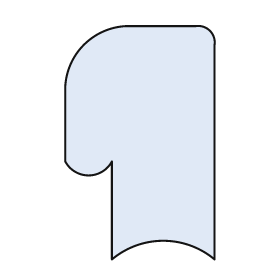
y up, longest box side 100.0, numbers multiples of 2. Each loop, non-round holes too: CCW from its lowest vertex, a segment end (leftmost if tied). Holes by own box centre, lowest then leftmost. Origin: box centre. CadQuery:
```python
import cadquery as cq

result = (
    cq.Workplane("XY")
    .moveTo(-12.0, -50.0)
    .threePointArc((10.0, -42.0), (32.0, -50.0))
    .lineTo(32.0, 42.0)
    .threePointArc((30.0, 48.0), (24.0, 50.0))
    .lineTo(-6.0, 50.0)
    .threePointArc((-24.0, 42.0), (-32.0, 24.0))
    .lineTo(-32.0, -8.0)
    .threePointArc((-22.0, -14.0), (-12.0, -8.0))
    .close()
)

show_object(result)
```